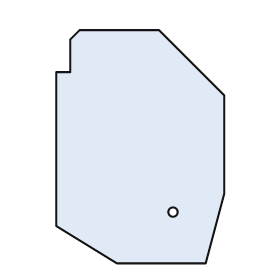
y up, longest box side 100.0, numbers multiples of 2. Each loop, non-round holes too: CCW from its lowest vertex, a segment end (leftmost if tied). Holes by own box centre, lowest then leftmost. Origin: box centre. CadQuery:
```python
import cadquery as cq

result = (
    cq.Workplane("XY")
    .moveTo(-10.0, -50.0)
    .lineTo(28.0, -50.0)
    .lineTo(36.0, -20.0)
    .lineTo(36.0, 22.0)
    .lineTo(8.0, 50.0)
    .lineTo(-26.0, 50.0)
    .lineTo(-30.0, 46.0)
    .lineTo(-30.0, 32.0)
    .lineTo(-36.0, 32.0)
    .lineTo(-36.0, -34.0)
    .close()
    .moveTo(14.0, -28.0)
    .circle(2.0)
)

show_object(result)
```